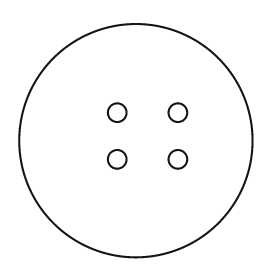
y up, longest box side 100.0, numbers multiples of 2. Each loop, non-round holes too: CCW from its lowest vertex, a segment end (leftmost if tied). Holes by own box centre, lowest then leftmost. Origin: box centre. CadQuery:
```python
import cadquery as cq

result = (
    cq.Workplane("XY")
    .moveTo(0.0, 0.0)
    .circle(50.0)
    .moveTo(-8.0, -8.0)
    .circle(4.0)
    .moveTo(18.0, -8.0)
    .circle(4.0)
    .moveTo(-8.0, 12.0)
    .circle(4.0)
    .moveTo(18.0, 12.0)
    .circle(4.0)
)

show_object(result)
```